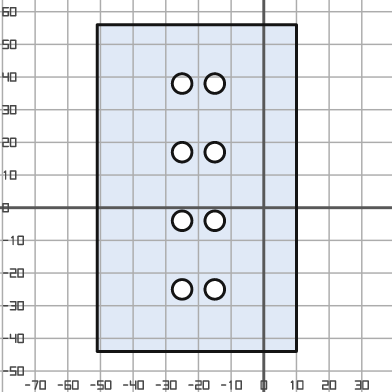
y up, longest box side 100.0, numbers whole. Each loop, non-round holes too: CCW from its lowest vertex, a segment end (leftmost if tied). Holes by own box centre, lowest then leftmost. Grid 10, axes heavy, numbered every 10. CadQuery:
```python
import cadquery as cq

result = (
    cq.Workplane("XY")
    .moveTo(-51.0, -44.0)
    .lineTo(10.0, -44.0)
    .lineTo(10.0, 56.0)
    .lineTo(-51.0, 56.0)
    .close()
    .moveTo(-25.0, -25.0)
    .circle(3.0)
    .moveTo(-15.0, -25.0)
    .circle(3.0)
    .moveTo(-25.0, -4.0)
    .circle(3.0)
    .moveTo(-15.0, -4.0)
    .circle(3.0)
    .moveTo(-25.0, 17.0)
    .circle(3.0)
    .moveTo(-15.0, 17.0)
    .circle(3.0)
    .moveTo(-25.0, 38.0)
    .circle(3.0)
    .moveTo(-15.0, 38.0)
    .circle(3.0)
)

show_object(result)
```